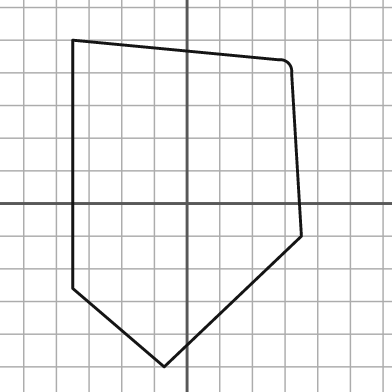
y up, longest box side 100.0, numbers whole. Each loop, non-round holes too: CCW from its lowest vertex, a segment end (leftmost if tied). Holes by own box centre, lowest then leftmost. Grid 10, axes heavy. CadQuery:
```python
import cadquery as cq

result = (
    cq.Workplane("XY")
    .moveTo(-7.0, -50.0)
    .lineTo(35.0, -10.0)
    .lineTo(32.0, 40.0)
    .threePointArc((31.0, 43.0), (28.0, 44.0))
    .lineTo(-35.0, 50.0)
    .lineTo(-35.0, -26.0)
    .close()
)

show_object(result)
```